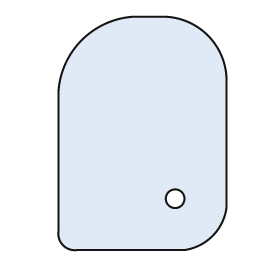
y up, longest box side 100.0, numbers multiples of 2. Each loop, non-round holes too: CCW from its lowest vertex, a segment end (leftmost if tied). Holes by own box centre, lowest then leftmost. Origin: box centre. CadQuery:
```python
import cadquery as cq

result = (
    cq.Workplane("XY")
    .moveTo(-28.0, -50.0)
    .lineTo(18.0, -50.0)
    .threePointArc((30.0, -44.0), (36.0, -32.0))
    .lineTo(36.0, 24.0)
    .threePointArc((28.0, 42.0), (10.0, 50.0))
    .lineTo(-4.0, 50.0)
    .threePointArc((-26.0, 40.0), (-36.0, 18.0))
    .lineTo(-36.0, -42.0)
    .threePointArc((-34.0, -48.0), (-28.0, -50.0))
    .close()
    .moveTo(14.0, -28.0)
    .circle(4.0)
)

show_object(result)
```